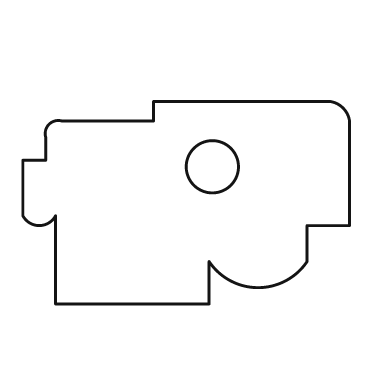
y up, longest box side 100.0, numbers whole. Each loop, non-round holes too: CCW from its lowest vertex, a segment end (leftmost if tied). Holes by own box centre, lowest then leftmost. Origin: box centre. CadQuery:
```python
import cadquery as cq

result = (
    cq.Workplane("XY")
    .moveTo(-40.0, -31.0)
    .lineTo(7.0, -31.0)
    .lineTo(7.0, -18.0)
    .threePointArc((22.0, -26.0), (37.0, -18.0))
    .lineTo(37.0, -7.0)
    .lineTo(50.0, -7.0)
    .lineTo(50.0, 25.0)
    .threePointArc((48.0, 29.0), (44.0, 31.0))
    .lineTo(-10.0, 31.0)
    .lineTo(-10.0, 25.0)
    .lineTo(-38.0, 25.0)
    .threePointArc((-42.0, 24.0), (-43.0, 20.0))
    .lineTo(-43.0, 13.0)
    .lineTo(-50.0, 13.0)
    .lineTo(-50.0, -4.0)
    .threePointArc((-45.0, -7.0), (-40.0, -4.0))
    .close()
    .moveTo(8.0, 11.0)
    .circle(8.0)
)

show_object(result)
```